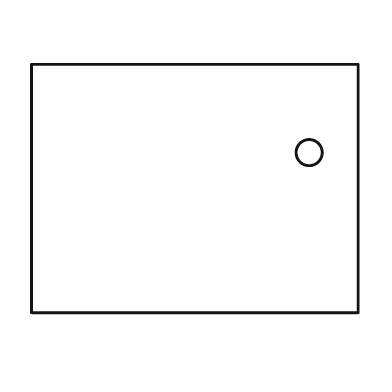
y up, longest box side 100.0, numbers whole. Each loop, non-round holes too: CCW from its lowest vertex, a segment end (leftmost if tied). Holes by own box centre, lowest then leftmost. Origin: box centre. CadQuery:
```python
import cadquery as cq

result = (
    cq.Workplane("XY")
    .moveTo(-50.0, -38.0)
    .lineTo(50.0, -38.0)
    .lineTo(50.0, 38.0)
    .lineTo(-50.0, 38.0)
    .close()
    .moveTo(35.0, 11.0)
    .circle(4.0)
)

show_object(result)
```